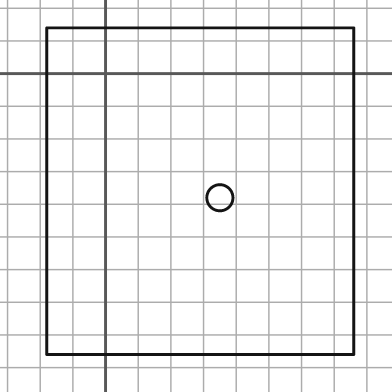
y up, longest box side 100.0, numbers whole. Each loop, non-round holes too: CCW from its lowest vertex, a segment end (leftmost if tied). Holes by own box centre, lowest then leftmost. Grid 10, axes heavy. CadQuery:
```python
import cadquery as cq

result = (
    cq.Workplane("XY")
    .moveTo(-18.0, -86.0)
    .lineTo(76.0, -86.0)
    .lineTo(76.0, 14.0)
    .lineTo(-18.0, 14.0)
    .close()
    .moveTo(35.0, -38.0)
    .circle(4.0)
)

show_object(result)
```